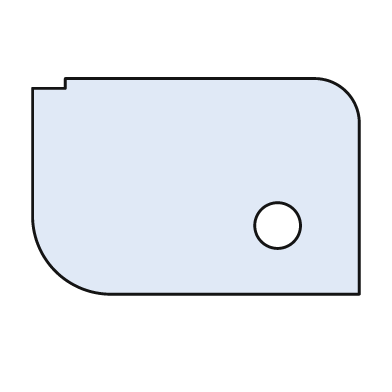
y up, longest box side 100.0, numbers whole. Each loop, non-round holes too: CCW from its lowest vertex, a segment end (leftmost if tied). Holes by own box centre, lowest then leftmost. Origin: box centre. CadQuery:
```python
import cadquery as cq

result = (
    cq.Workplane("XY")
    .moveTo(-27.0, -33.0)
    .lineTo(50.0, -33.0)
    .lineTo(50.0, 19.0)
    .threePointArc((46.0, 29.0), (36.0, 33.0))
    .lineTo(-40.0, 33.0)
    .lineTo(-40.0, 30.0)
    .lineTo(-50.0, 30.0)
    .lineTo(-50.0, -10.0)
    .threePointArc((-43.0, -26.0), (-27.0, -33.0))
    .close()
    .moveTo(25.0, -12.0)
    .circle(7.0)
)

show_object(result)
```